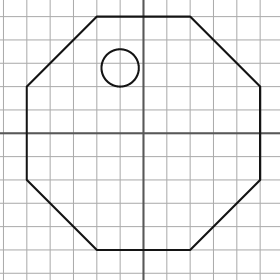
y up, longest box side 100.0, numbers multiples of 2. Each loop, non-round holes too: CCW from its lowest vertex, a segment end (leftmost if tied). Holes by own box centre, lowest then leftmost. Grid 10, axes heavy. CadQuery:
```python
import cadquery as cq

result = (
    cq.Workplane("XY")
    .moveTo(-20.0, -50.0)
    .lineTo(20.0, -50.0)
    .lineTo(50.0, -20.0)
    .lineTo(50.0, 20.0)
    .lineTo(20.0, 50.0)
    .lineTo(-20.0, 50.0)
    .lineTo(-50.0, 20.0)
    .lineTo(-50.0, -20.0)
    .close()
    .moveTo(-10.0, 28.0)
    .circle(8.0)
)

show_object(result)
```